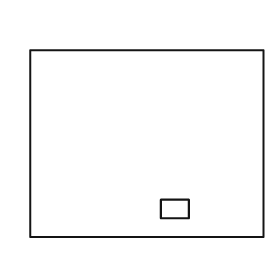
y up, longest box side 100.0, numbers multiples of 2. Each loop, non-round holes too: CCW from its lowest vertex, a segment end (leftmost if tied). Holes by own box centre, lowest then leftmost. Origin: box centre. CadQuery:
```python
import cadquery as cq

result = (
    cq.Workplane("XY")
    .moveTo(-50.0, -40.0)
    .lineTo(50.0, -40.0)
    .lineTo(50.0, 40.0)
    .lineTo(-50.0, 40.0)
    .close()
    .moveTo(6.0, -32.0)
    .lineTo(18.0, -32.0)
    .lineTo(18.0, -24.0)
    .lineTo(6.0, -24.0)
    .close()
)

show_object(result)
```